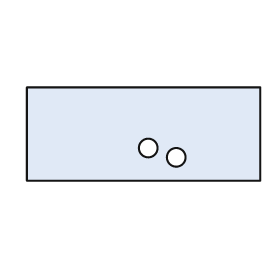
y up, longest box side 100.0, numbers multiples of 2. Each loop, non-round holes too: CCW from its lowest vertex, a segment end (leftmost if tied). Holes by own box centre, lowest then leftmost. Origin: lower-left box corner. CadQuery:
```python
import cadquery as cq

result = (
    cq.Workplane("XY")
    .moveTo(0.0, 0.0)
    .lineTo(100.0, 0.0)
    .lineTo(100.0, 40.0)
    .lineTo(0.0, 40.0)
    .close()
    .moveTo(64.0, 10.0)
    .circle(4.0)
    .moveTo(52.0, 14.0)
    .circle(4.0)
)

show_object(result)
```